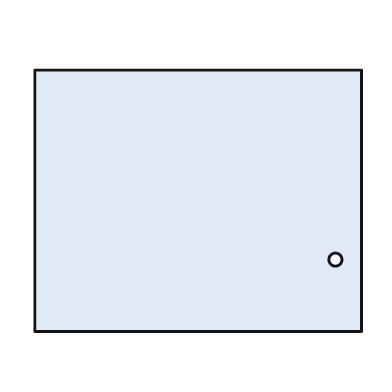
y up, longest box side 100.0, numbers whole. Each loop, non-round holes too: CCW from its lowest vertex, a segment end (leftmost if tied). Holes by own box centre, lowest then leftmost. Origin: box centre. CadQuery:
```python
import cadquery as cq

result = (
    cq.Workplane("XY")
    .moveTo(-50.0, -40.0)
    .lineTo(50.0, -40.0)
    .lineTo(50.0, 40.0)
    .lineTo(-50.0, 40.0)
    .close()
    .moveTo(42.0, -18.0)
    .circle(2.0)
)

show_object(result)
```